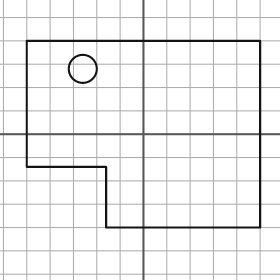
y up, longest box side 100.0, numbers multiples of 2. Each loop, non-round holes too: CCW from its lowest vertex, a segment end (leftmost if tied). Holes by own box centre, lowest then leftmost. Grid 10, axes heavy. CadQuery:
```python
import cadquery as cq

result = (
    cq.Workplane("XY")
    .moveTo(-16.0, -40.0)
    .lineTo(50.0, -40.0)
    .lineTo(50.0, 40.0)
    .lineTo(-50.0, 40.0)
    .lineTo(-50.0, -14.0)
    .lineTo(-16.0, -14.0)
    .close()
    .moveTo(-26.0, 28.0)
    .circle(6.0)
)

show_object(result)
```